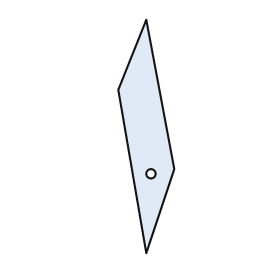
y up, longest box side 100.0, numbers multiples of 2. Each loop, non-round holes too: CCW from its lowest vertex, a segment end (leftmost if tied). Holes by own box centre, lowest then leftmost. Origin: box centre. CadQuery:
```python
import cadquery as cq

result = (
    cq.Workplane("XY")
    .moveTo(0.0, -50.0)
    .lineTo(12.0, -14.0)
    .lineTo(0.0, 50.0)
    .lineTo(-12.0, 20.0)
    .close()
    .moveTo(2.0, -16.0)
    .circle(2.0)
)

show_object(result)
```